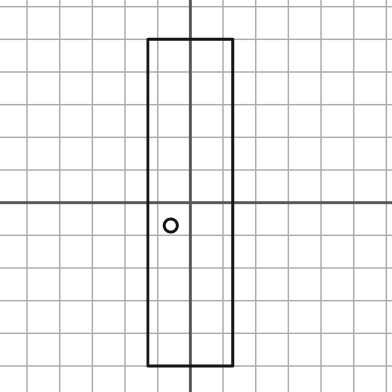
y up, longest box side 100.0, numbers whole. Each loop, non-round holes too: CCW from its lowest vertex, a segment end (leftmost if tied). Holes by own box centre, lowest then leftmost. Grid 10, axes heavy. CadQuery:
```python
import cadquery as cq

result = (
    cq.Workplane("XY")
    .moveTo(-13.0, -50.0)
    .lineTo(13.0, -50.0)
    .lineTo(13.0, 50.0)
    .lineTo(-13.0, 50.0)
    .close()
    .moveTo(-6.0, -7.0)
    .circle(2.0)
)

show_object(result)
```